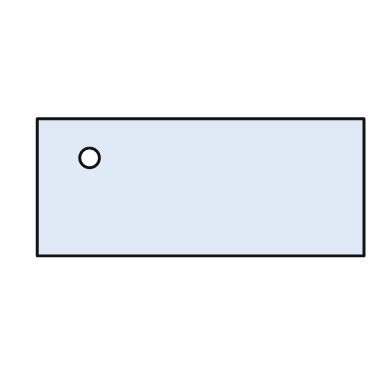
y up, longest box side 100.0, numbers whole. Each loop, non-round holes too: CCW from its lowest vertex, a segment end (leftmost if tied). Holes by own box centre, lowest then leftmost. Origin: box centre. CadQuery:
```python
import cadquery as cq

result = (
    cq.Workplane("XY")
    .moveTo(-50.0, -21.0)
    .lineTo(50.0, -21.0)
    .lineTo(50.0, 21.0)
    .lineTo(-50.0, 21.0)
    .close()
    .moveTo(-34.0, 9.0)
    .circle(3.0)
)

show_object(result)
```